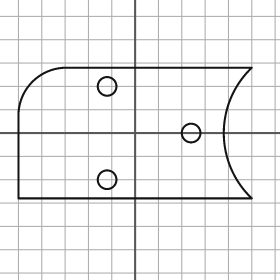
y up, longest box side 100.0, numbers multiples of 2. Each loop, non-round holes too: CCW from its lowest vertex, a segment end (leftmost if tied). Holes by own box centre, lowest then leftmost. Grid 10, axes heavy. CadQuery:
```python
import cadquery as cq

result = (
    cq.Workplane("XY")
    .moveTo(-50.0, -28.0)
    .lineTo(50.0, -28.0)
    .threePointArc((38.0, 0.0), (50.0, 28.0))
    .lineTo(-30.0, 28.0)
    .threePointArc((-44.0, 22.0), (-50.0, 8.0))
    .close()
    .moveTo(-12.0, -20.0)
    .circle(4.0)
    .moveTo(24.0, 0.0)
    .circle(4.0)
    .moveTo(-12.0, 20.0)
    .circle(4.0)
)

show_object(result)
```